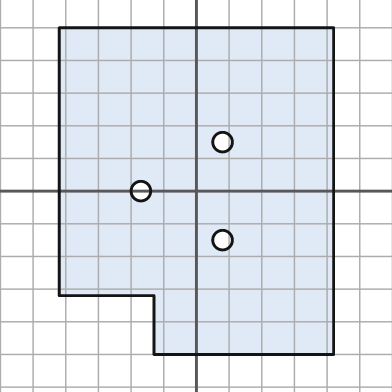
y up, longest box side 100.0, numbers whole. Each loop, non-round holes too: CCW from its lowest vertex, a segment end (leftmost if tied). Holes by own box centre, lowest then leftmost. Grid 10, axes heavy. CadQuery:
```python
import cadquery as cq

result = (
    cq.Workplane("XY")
    .moveTo(-13.0, -50.0)
    .lineTo(42.0, -50.0)
    .lineTo(42.0, 50.0)
    .lineTo(-42.0, 50.0)
    .lineTo(-42.0, -32.0)
    .lineTo(-13.0, -32.0)
    .close()
    .moveTo(8.0, -15.0)
    .circle(3.0)
    .moveTo(-17.0, 0.0)
    .circle(3.0)
    .moveTo(8.0, 15.0)
    .circle(3.0)
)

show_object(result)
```